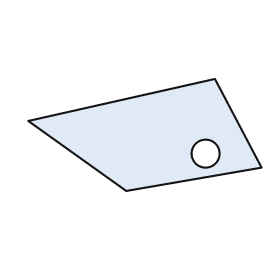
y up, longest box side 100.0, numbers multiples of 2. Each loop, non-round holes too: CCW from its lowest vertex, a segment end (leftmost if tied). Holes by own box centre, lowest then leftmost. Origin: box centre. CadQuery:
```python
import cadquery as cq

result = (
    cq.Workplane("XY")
    .moveTo(-8.0, -24.0)
    .lineTo(50.0, -14.0)
    .lineTo(30.0, 24.0)
    .lineTo(-50.0, 6.0)
    .close()
    .moveTo(26.0, -8.0)
    .circle(6.0)
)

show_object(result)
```